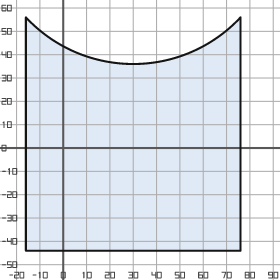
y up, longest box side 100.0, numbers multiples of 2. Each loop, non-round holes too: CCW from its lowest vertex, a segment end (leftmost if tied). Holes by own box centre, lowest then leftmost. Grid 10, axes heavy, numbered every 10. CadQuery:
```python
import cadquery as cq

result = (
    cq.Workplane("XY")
    .moveTo(-16.0, -44.0)
    .lineTo(76.0, -44.0)
    .lineTo(76.0, 56.0)
    .threePointArc((30.0, 36.0), (-16.0, 56.0))
    .close()
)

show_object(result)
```